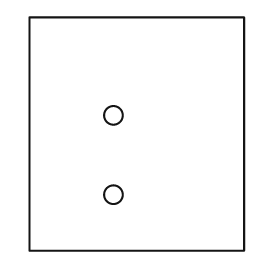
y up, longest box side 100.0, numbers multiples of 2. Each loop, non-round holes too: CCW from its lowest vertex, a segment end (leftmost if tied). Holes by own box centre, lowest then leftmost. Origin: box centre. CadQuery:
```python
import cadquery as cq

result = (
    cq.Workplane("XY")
    .moveTo(-46.0, -50.0)
    .lineTo(46.0, -50.0)
    .lineTo(46.0, 50.0)
    .lineTo(-46.0, 50.0)
    .close()
    .moveTo(-10.0, -26.0)
    .circle(4.0)
    .moveTo(-10.0, 8.0)
    .circle(4.0)
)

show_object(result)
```